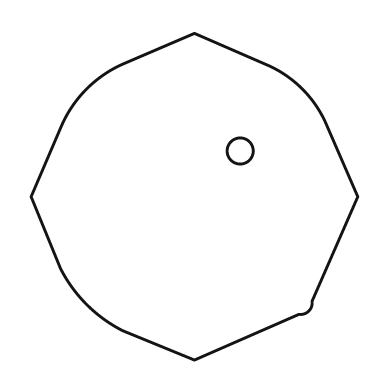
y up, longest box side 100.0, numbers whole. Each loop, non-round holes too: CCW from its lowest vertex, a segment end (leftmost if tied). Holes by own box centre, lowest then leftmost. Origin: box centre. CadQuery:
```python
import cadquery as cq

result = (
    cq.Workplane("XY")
    .moveTo(0.0, -50.0)
    .lineTo(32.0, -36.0)
    .threePointArc((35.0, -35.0), (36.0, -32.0))
    .lineTo(50.0, 0.0)
    .lineTo(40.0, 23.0)
    .threePointArc((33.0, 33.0), (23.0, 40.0))
    .lineTo(0.0, 50.0)
    .lineTo(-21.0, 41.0)
    .threePointArc((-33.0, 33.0), (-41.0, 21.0))
    .lineTo(-50.0, 0.0)
    .lineTo(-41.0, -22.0)
    .threePointArc((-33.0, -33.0), (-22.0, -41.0))
    .close()
    .moveTo(14.0, 14.0)
    .circle(4.0)
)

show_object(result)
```